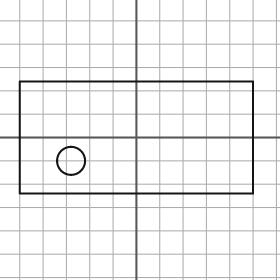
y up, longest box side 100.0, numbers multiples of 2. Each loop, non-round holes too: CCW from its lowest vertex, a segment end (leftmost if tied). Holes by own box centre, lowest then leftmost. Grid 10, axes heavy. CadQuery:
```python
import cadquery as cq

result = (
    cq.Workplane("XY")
    .moveTo(-50.0, -24.0)
    .lineTo(50.0, -24.0)
    .lineTo(50.0, 24.0)
    .lineTo(-50.0, 24.0)
    .close()
    .moveTo(-28.0, -10.0)
    .circle(6.0)
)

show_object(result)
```